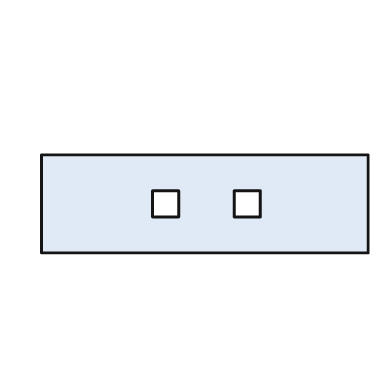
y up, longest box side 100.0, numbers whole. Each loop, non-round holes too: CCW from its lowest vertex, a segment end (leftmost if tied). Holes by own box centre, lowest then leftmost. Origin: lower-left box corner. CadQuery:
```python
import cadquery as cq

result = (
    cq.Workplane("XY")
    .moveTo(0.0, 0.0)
    .lineTo(100.0, 0.0)
    .lineTo(100.0, 30.0)
    .lineTo(0.0, 30.0)
    .close()
    .moveTo(34.0, 11.0)
    .lineTo(42.0, 11.0)
    .lineTo(42.0, 19.0)
    .lineTo(34.0, 19.0)
    .close()
    .moveTo(59.0, 11.0)
    .lineTo(67.0, 11.0)
    .lineTo(67.0, 19.0)
    .lineTo(59.0, 19.0)
    .close()
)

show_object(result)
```